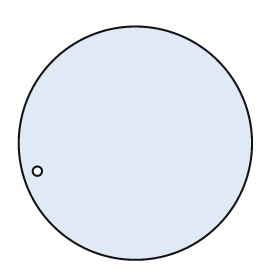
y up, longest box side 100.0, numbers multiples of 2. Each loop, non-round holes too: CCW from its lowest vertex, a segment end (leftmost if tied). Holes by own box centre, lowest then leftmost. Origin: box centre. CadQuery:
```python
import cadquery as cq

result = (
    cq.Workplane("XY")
    .moveTo(0.0, 0.0)
    .circle(50.0)
    .moveTo(-42.0, -12.0)
    .circle(2.0)
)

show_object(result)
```